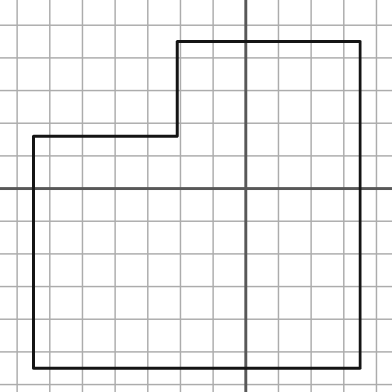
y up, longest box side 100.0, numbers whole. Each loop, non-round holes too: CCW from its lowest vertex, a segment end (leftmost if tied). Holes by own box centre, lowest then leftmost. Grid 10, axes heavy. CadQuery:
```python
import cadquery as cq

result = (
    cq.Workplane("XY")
    .moveTo(-65.0, -55.0)
    .lineTo(35.0, -55.0)
    .lineTo(35.0, 45.0)
    .lineTo(-21.0, 45.0)
    .lineTo(-21.0, 16.0)
    .lineTo(-65.0, 16.0)
    .close()
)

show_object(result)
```